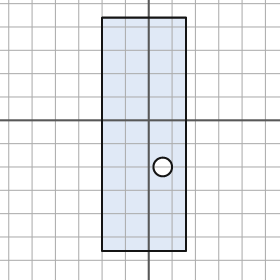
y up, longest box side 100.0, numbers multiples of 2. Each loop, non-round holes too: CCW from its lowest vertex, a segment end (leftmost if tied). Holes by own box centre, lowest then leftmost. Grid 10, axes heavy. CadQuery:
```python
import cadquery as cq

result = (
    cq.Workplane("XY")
    .moveTo(-20.0, -56.0)
    .lineTo(16.0, -56.0)
    .lineTo(16.0, 44.0)
    .lineTo(-20.0, 44.0)
    .close()
    .moveTo(6.0, -20.0)
    .circle(4.0)
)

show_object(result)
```